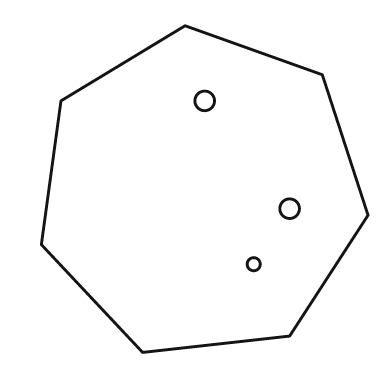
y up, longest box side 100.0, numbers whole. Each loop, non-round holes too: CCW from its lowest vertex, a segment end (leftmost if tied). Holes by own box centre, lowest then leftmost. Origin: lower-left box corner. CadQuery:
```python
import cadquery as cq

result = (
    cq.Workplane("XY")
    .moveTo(31.0, 0.0)
    .lineTo(76.0, 5.0)
    .lineTo(100.0, 42.0)
    .lineTo(86.0, 85.0)
    .lineTo(44.0, 100.0)
    .lineTo(6.0, 77.0)
    .lineTo(0.0, 33.0)
    .close()
    .moveTo(65.0, 27.0)
    .circle(2.0)
    .moveTo(76.0, 44.0)
    .circle(3.0)
    .moveTo(50.0, 77.0)
    .circle(3.0)
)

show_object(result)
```